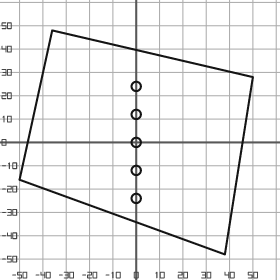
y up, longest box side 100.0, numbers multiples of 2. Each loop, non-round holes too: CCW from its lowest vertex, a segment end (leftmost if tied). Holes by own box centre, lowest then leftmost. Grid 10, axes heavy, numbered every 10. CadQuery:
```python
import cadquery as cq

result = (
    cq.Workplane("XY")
    .moveTo(38.0, -48.0)
    .lineTo(50.0, 28.0)
    .lineTo(-36.0, 48.0)
    .lineTo(-50.0, -16.0)
    .close()
    .moveTo(0.0, -24.0)
    .circle(2.0)
    .moveTo(0.0, -12.0)
    .circle(2.0)
    .moveTo(0.0, 0.0)
    .circle(2.0)
    .moveTo(0.0, 12.0)
    .circle(2.0)
    .moveTo(0.0, 24.0)
    .circle(2.0)
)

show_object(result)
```